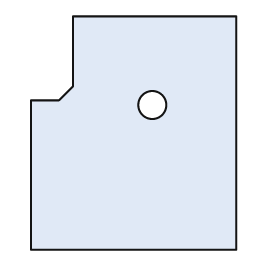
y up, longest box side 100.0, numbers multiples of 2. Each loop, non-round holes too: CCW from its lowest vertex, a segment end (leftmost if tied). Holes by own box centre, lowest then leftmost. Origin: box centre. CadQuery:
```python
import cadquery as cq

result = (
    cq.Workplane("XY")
    .moveTo(-44.0, -50.0)
    .lineTo(44.0, -50.0)
    .lineTo(44.0, 50.0)
    .lineTo(-26.0, 50.0)
    .lineTo(-26.0, 20.0)
    .lineTo(-32.0, 14.0)
    .lineTo(-44.0, 14.0)
    .close()
    .moveTo(8.0, 12.0)
    .circle(6.0)
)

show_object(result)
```